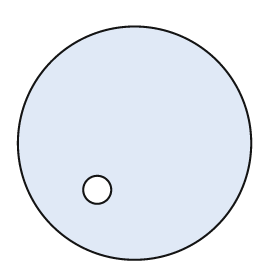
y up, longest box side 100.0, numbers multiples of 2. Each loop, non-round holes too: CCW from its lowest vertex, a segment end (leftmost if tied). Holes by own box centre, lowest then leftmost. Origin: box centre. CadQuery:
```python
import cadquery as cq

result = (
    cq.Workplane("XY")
    .moveTo(0.0, 0.0)
    .circle(50.0)
    .moveTo(-16.0, -20.0)
    .circle(6.0)
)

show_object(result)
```